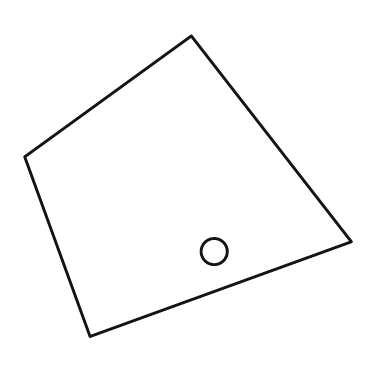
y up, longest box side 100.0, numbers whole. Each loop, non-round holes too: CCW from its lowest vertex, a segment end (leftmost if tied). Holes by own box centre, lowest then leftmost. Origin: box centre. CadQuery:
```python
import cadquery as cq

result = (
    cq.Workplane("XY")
    .moveTo(-30.0, -46.0)
    .lineTo(50.0, -17.0)
    .lineTo(1.0, 46.0)
    .lineTo(-50.0, 9.0)
    .close()
    .moveTo(8.0, -20.0)
    .circle(4.0)
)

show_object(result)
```